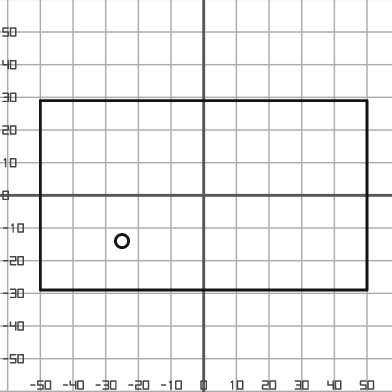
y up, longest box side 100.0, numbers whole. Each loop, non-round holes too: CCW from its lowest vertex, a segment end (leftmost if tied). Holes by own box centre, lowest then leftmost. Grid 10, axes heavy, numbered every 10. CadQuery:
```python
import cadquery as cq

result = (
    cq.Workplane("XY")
    .moveTo(-50.0, -29.0)
    .lineTo(50.0, -29.0)
    .lineTo(50.0, 29.0)
    .lineTo(-50.0, 29.0)
    .close()
    .moveTo(-25.0, -14.0)
    .circle(2.0)
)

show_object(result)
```